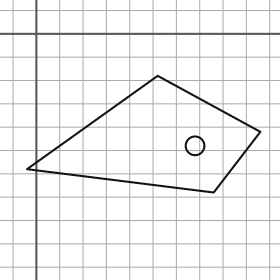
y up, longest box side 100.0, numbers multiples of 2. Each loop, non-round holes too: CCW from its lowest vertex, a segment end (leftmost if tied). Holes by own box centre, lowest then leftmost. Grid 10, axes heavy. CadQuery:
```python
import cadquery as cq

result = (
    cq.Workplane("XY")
    .moveTo(76.0, -68.0)
    .lineTo(96.0, -42.0)
    .lineTo(52.0, -18.0)
    .lineTo(-4.0, -58.0)
    .close()
    .moveTo(68.0, -48.0)
    .circle(4.0)
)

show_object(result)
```